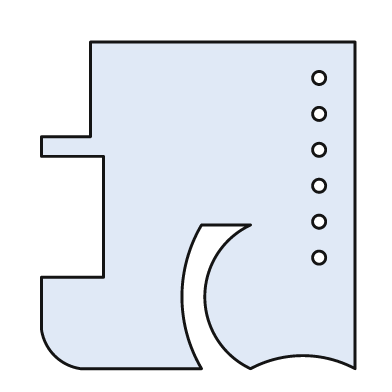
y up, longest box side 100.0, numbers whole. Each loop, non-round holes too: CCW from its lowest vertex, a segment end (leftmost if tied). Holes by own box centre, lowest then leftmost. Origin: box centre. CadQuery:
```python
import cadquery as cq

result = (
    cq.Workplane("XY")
    .moveTo(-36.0, -50.0)
    .lineTo(1.0, -50.0)
    .threePointArc((-5.0, -28.0), (1.0, -6.0))
    .lineTo(16.0, -6.0)
    .threePointArc((2.0, -28.0), (16.0, -50.0))
    .threePointArc((32.0, -46.0), (48.0, -50.0))
    .lineTo(48.0, 50.0)
    .lineTo(-33.0, 50.0)
    .lineTo(-33.0, 21.0)
    .lineTo(-48.0, 21.0)
    .lineTo(-48.0, 15.0)
    .lineTo(-29.0, 15.0)
    .lineTo(-29.0, -22.0)
    .lineTo(-48.0, -22.0)
    .lineTo(-48.0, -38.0)
    .threePointArc((-44.0, -46.0), (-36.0, -50.0))
    .close()
    .moveTo(37.0, -16.0)
    .circle(2.0)
    .moveTo(37.0, -5.0)
    .circle(2.0)
    .moveTo(37.0, 6.0)
    .circle(2.0)
    .moveTo(37.0, 17.0)
    .circle(2.0)
    .moveTo(37.0, 28.0)
    .circle(2.0)
    .moveTo(37.0, 39.0)
    .circle(2.0)
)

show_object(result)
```